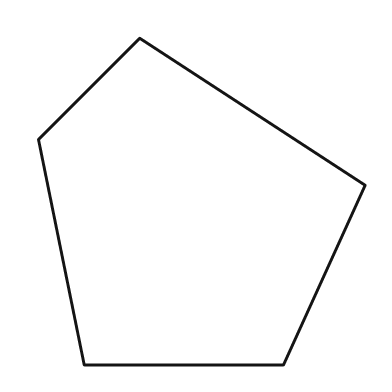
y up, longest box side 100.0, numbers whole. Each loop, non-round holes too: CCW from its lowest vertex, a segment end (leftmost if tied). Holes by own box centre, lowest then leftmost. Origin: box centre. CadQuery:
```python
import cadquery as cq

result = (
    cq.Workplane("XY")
    .moveTo(-36.0, -50.0)
    .lineTo(25.0, -50.0)
    .lineTo(50.0, 5.0)
    .lineTo(-19.0, 50.0)
    .lineTo(-50.0, 19.0)
    .close()
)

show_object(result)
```